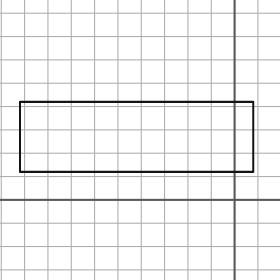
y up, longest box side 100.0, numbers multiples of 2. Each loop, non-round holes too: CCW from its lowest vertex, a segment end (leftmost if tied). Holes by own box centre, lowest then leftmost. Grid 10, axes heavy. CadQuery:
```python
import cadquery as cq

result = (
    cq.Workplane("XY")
    .moveTo(-92.0, 12.0)
    .lineTo(8.0, 12.0)
    .lineTo(8.0, 42.0)
    .lineTo(-92.0, 42.0)
    .close()
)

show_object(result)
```